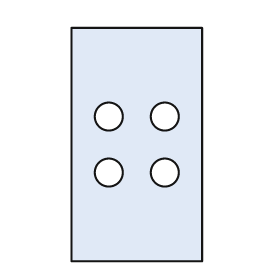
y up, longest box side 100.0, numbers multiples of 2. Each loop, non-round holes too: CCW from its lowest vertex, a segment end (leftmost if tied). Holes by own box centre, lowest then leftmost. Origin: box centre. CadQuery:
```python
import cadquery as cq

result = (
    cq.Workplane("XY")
    .moveTo(-28.0, -50.0)
    .lineTo(28.0, -50.0)
    .lineTo(28.0, 50.0)
    .lineTo(-28.0, 50.0)
    .close()
    .moveTo(-12.0, -12.0)
    .circle(6.0)
    .moveTo(12.0, -12.0)
    .circle(6.0)
    .moveTo(-12.0, 12.0)
    .circle(6.0)
    .moveTo(12.0, 12.0)
    .circle(6.0)
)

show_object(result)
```